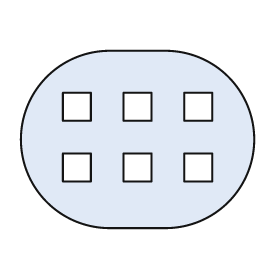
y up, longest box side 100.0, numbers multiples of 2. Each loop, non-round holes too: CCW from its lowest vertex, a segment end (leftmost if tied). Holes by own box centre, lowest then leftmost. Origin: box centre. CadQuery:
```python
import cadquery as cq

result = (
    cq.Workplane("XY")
    .moveTo(-12.0, -38.0)
    .lineTo(12.0, -38.0)
    .threePointArc((50.0, 0.0), (12.0, 38.0))
    .lineTo(-12.0, 38.0)
    .threePointArc((-50.0, 0.0), (-12.0, -38.0))
    .close()
    .moveTo(-32.0, -18.0)
    .lineTo(-20.0, -18.0)
    .lineTo(-20.0, -6.0)
    .lineTo(-32.0, -6.0)
    .close()
    .moveTo(-6.0, -18.0)
    .lineTo(6.0, -18.0)
    .lineTo(6.0, -6.0)
    .lineTo(-6.0, -6.0)
    .close()
    .moveTo(20.0, -18.0)
    .lineTo(32.0, -18.0)
    .lineTo(32.0, -6.0)
    .lineTo(20.0, -6.0)
    .close()
    .moveTo(-32.0, 8.0)
    .lineTo(-20.0, 8.0)
    .lineTo(-20.0, 20.0)
    .lineTo(-32.0, 20.0)
    .close()
    .moveTo(-6.0, 8.0)
    .lineTo(6.0, 8.0)
    .lineTo(6.0, 20.0)
    .lineTo(-6.0, 20.0)
    .close()
    .moveTo(20.0, 8.0)
    .lineTo(32.0, 8.0)
    .lineTo(32.0, 20.0)
    .lineTo(20.0, 20.0)
    .close()
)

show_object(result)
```